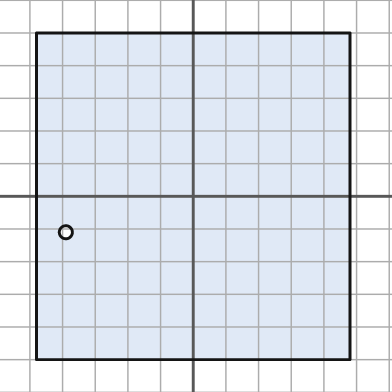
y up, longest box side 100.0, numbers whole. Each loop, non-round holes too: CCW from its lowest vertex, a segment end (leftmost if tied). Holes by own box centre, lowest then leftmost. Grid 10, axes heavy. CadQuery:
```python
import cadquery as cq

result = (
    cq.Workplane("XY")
    .moveTo(-48.0, -50.0)
    .lineTo(48.0, -50.0)
    .lineTo(48.0, 50.0)
    .lineTo(-48.0, 50.0)
    .close()
    .moveTo(-39.0, -11.0)
    .circle(2.0)
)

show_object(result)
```